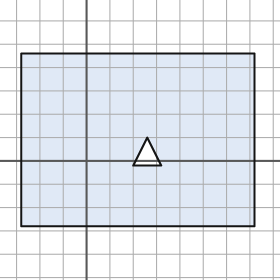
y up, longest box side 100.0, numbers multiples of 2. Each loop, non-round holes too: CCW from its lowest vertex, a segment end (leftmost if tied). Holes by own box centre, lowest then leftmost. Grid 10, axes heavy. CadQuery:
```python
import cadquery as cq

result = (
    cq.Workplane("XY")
    .moveTo(-28.0, -28.0)
    .lineTo(72.0, -28.0)
    .lineTo(72.0, 46.0)
    .lineTo(-28.0, 46.0)
    .close()
    .moveTo(20.0, -2.0)
    .lineTo(32.0, -2.0)
    .lineTo(26.0, 10.0)
    .close()
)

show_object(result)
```